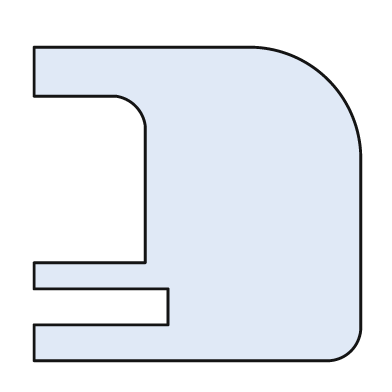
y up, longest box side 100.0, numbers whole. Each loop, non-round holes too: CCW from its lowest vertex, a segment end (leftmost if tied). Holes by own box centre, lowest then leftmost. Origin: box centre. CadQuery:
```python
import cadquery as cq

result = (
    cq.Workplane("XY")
    .moveTo(-50.0, -48.0)
    .lineTo(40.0, -48.0)
    .threePointArc((47.0, -45.0), (50.0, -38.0))
    .lineTo(50.0, 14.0)
    .threePointArc((40.0, 38.0), (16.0, 48.0))
    .lineTo(-50.0, 48.0)
    .lineTo(-50.0, 33.0)
    .lineTo(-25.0, 33.0)
    .threePointArc((-19.0, 30.0), (-16.0, 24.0))
    .lineTo(-16.0, -18.0)
    .lineTo(-50.0, -18.0)
    .lineTo(-50.0, -26.0)
    .lineTo(-9.0, -26.0)
    .lineTo(-9.0, -37.0)
    .lineTo(-50.0, -37.0)
    .close()
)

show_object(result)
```